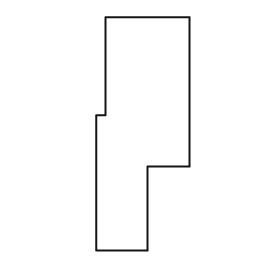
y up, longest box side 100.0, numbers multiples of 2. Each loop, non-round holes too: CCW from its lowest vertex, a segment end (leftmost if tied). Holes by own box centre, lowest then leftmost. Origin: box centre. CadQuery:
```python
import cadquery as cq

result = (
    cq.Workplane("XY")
    .moveTo(-20.0, -50.0)
    .lineTo(2.0, -50.0)
    .lineTo(2.0, -14.0)
    .lineTo(20.0, -14.0)
    .lineTo(20.0, 50.0)
    .lineTo(-16.0, 50.0)
    .lineTo(-16.0, 8.0)
    .lineTo(-20.0, 8.0)
    .close()
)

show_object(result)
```